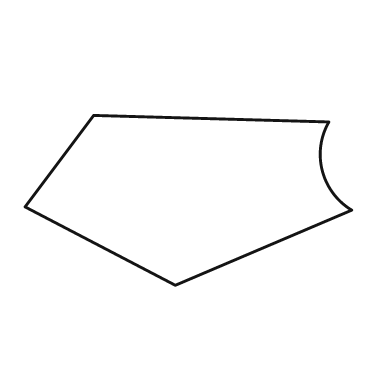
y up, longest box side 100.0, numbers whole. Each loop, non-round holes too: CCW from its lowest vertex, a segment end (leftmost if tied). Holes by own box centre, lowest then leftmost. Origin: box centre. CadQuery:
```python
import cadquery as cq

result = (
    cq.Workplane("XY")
    .moveTo(-4.0, -26.0)
    .lineTo(50.0, -3.0)
    .threePointArc((41.0, 9.0), (43.0, 24.0))
    .lineTo(-29.0, 26.0)
    .lineTo(-50.0, -2.0)
    .close()
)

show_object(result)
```